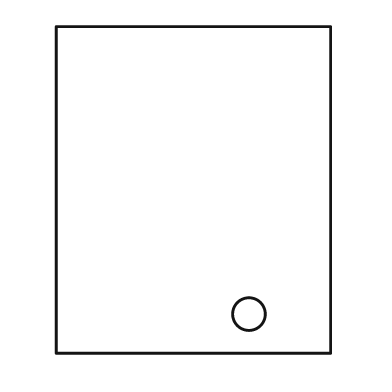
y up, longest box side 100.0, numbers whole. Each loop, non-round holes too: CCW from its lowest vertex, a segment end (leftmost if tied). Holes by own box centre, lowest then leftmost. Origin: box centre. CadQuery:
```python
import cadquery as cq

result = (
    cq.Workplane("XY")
    .moveTo(-42.0, -50.0)
    .lineTo(42.0, -50.0)
    .lineTo(42.0, 50.0)
    .lineTo(-42.0, 50.0)
    .close()
    .moveTo(17.0, -38.0)
    .circle(5.0)
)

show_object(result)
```